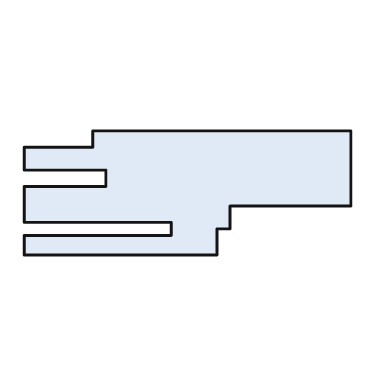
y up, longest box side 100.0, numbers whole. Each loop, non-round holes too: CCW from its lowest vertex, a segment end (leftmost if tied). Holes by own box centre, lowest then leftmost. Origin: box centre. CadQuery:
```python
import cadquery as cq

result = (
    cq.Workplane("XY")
    .moveTo(-50.0, -19.0)
    .lineTo(9.0, -19.0)
    .lineTo(9.0, -11.0)
    .lineTo(13.0, -11.0)
    .lineTo(13.0, -4.0)
    .lineTo(50.0, -4.0)
    .lineTo(50.0, 19.0)
    .lineTo(-29.0, 19.0)
    .lineTo(-29.0, 14.0)
    .lineTo(-50.0, 14.0)
    .lineTo(-50.0, 7.0)
    .lineTo(-25.0, 7.0)
    .lineTo(-25.0, 2.0)
    .lineTo(-50.0, 2.0)
    .lineTo(-50.0, -9.0)
    .lineTo(-5.0, -9.0)
    .lineTo(-5.0, -13.0)
    .lineTo(-50.0, -13.0)
    .close()
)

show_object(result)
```